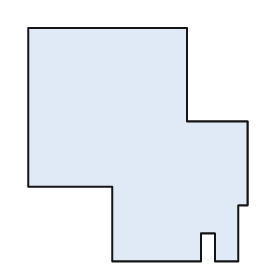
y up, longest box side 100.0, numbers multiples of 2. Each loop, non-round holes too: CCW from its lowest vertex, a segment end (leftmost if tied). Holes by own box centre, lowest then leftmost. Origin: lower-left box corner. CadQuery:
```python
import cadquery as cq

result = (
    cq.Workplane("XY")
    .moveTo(36.0, 0.0)
    .lineTo(74.0, 0.0)
    .lineTo(74.0, 12.0)
    .lineTo(80.0, 12.0)
    .lineTo(80.0, 0.0)
    .lineTo(90.0, 0.0)
    .lineTo(90.0, 24.0)
    .lineTo(94.0, 24.0)
    .lineTo(94.0, 60.0)
    .lineTo(68.0, 60.0)
    .lineTo(68.0, 100.0)
    .lineTo(0.0, 100.0)
    .lineTo(0.0, 32.0)
    .lineTo(36.0, 32.0)
    .close()
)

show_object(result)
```